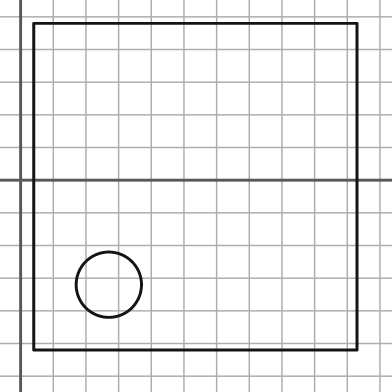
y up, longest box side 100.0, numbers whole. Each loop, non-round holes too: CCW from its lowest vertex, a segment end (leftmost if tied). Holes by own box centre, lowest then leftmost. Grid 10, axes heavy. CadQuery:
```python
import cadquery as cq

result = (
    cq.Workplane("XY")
    .moveTo(4.0, -52.0)
    .lineTo(103.0, -52.0)
    .lineTo(103.0, 48.0)
    .lineTo(4.0, 48.0)
    .close()
    .moveTo(27.0, -32.0)
    .circle(10.0)
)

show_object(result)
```